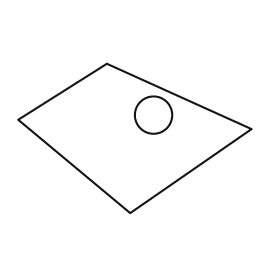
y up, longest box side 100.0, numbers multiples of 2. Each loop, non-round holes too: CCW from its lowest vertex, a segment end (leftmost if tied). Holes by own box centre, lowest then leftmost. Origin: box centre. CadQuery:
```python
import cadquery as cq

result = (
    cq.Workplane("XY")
    .moveTo(-2.0, -32.0)
    .lineTo(50.0, 4.0)
    .lineTo(-12.0, 32.0)
    .lineTo(-50.0, 8.0)
    .close()
    .moveTo(8.0, 10.0)
    .circle(8.0)
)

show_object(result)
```